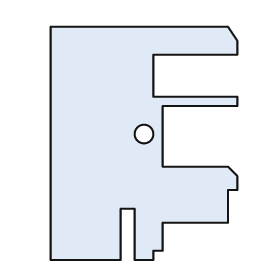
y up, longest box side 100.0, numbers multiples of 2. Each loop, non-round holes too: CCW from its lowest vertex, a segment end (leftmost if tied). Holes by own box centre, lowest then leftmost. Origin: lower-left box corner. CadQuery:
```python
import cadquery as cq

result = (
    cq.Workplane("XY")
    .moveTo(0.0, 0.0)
    .lineTo(30.0, 0.0)
    .lineTo(30.0, 22.0)
    .lineTo(36.0, 22.0)
    .lineTo(36.0, 0.0)
    .lineTo(44.0, 0.0)
    .lineTo(44.0, 4.0)
    .lineTo(48.0, 4.0)
    .lineTo(48.0, 16.0)
    .lineTo(76.0, 16.0)
    .lineTo(76.0, 30.0)
    .lineTo(80.0, 30.0)
    .lineTo(80.0, 36.0)
    .lineTo(76.0, 40.0)
    .lineTo(48.0, 40.0)
    .lineTo(48.0, 66.0)
    .lineTo(80.0, 66.0)
    .lineTo(80.0, 70.0)
    .lineTo(44.0, 70.0)
    .lineTo(44.0, 88.0)
    .lineTo(80.0, 88.0)
    .lineTo(80.0, 94.0)
    .lineTo(76.0, 100.0)
    .lineTo(0.0, 100.0)
    .close()
    .moveTo(40.0, 54.0)
    .circle(4.0)
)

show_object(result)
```